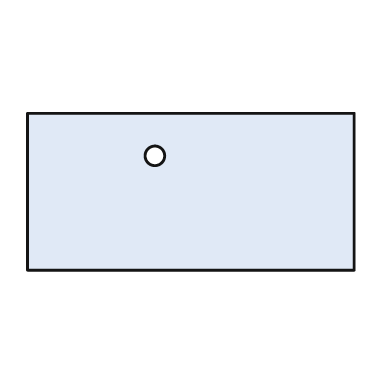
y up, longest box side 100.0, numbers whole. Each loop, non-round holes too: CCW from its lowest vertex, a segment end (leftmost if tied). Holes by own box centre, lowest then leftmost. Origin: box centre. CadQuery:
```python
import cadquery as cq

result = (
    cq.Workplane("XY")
    .moveTo(-50.0, -24.0)
    .lineTo(50.0, -24.0)
    .lineTo(50.0, 24.0)
    .lineTo(-50.0, 24.0)
    .close()
    .moveTo(-11.0, 11.0)
    .circle(3.0)
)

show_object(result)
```